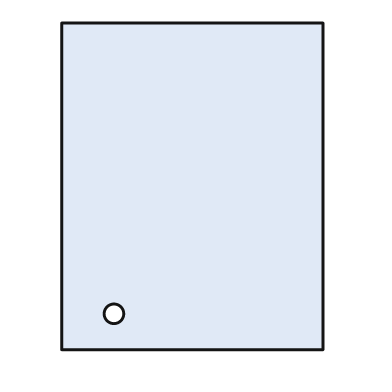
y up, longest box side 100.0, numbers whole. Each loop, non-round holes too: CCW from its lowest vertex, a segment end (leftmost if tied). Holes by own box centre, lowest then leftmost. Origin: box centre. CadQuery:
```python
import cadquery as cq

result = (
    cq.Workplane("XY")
    .moveTo(-40.0, -50.0)
    .lineTo(40.0, -50.0)
    .lineTo(40.0, 50.0)
    .lineTo(-40.0, 50.0)
    .close()
    .moveTo(-24.0, -39.0)
    .circle(3.0)
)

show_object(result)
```